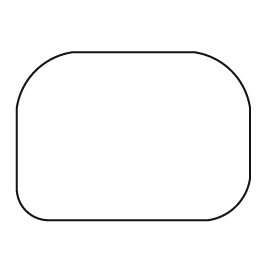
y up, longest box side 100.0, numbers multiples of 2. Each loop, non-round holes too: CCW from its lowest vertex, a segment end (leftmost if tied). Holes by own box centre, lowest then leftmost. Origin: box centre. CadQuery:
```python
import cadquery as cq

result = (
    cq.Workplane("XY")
    .moveTo(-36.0, -36.0)
    .lineTo(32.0, -36.0)
    .threePointArc((44.0, -30.0), (50.0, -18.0))
    .lineTo(50.0, 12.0)
    .threePointArc((42.0, 28.0), (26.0, 36.0))
    .lineTo(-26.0, 36.0)
    .threePointArc((-42.0, 28.0), (-50.0, 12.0))
    .lineTo(-50.0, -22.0)
    .threePointArc((-46.0, -32.0), (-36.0, -36.0))
    .close()
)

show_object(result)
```